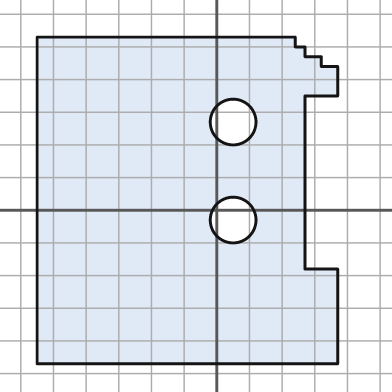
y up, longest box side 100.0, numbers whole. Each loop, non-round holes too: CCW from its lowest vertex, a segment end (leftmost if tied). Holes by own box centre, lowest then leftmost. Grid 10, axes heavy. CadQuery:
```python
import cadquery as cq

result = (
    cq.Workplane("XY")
    .moveTo(-55.0, -47.0)
    .lineTo(37.0, -47.0)
    .lineTo(37.0, -18.0)
    .lineTo(27.0, -18.0)
    .lineTo(27.0, 35.0)
    .lineTo(37.0, 35.0)
    .lineTo(37.0, 44.0)
    .lineTo(32.0, 44.0)
    .lineTo(32.0, 47.0)
    .lineTo(27.0, 47.0)
    .lineTo(27.0, 50.0)
    .lineTo(24.0, 50.0)
    .lineTo(24.0, 53.0)
    .lineTo(-55.0, 53.0)
    .close()
    .moveTo(5.0, -3.0)
    .circle(7.0)
    .moveTo(5.0, 27.0)
    .circle(7.0)
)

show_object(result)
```